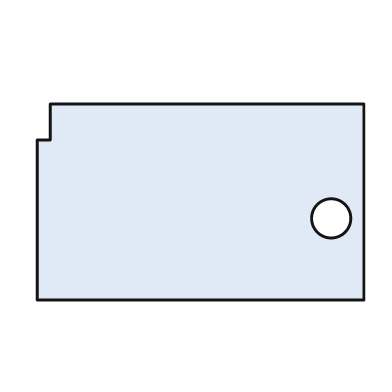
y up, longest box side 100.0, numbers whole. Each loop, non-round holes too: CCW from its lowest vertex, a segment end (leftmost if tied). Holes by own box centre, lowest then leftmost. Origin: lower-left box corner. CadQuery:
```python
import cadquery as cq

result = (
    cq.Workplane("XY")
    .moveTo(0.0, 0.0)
    .lineTo(100.0, 0.0)
    .lineTo(100.0, 60.0)
    .lineTo(4.0, 60.0)
    .lineTo(4.0, 49.0)
    .lineTo(0.0, 49.0)
    .close()
    .moveTo(90.0, 25.0)
    .circle(6.0)
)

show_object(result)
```